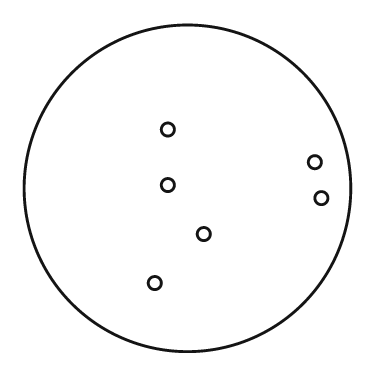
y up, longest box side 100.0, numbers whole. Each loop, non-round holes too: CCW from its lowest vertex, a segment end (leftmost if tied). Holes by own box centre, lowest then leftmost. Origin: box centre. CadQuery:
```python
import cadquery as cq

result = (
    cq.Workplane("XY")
    .moveTo(0.0, 0.0)
    .circle(50.0)
    .moveTo(-10.0, -29.0)
    .circle(2.0)
    .moveTo(5.0, -14.0)
    .circle(2.0)
    .moveTo(41.0, -3.0)
    .circle(2.0)
    .moveTo(-6.0, 1.0)
    .circle(2.0)
    .moveTo(39.0, 8.0)
    .circle(2.0)
    .moveTo(-6.0, 18.0)
    .circle(2.0)
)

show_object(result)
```